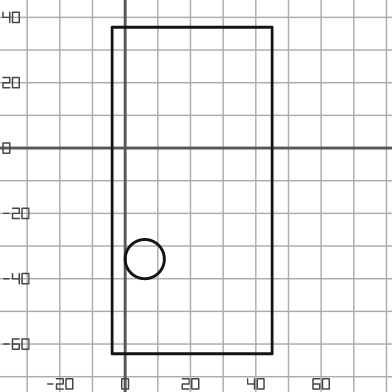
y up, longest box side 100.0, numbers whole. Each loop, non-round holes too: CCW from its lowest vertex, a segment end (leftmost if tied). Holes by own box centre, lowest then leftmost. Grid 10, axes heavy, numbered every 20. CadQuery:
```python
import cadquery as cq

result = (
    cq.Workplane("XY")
    .moveTo(-4.0, -63.0)
    .lineTo(45.0, -63.0)
    .lineTo(45.0, 37.0)
    .lineTo(-4.0, 37.0)
    .close()
    .moveTo(6.0, -34.0)
    .circle(6.0)
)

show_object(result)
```